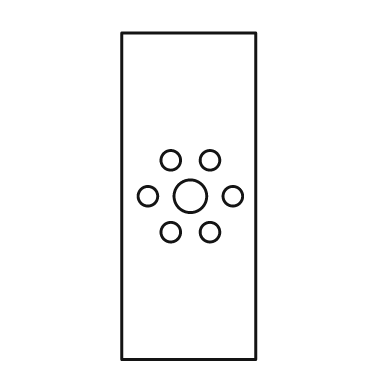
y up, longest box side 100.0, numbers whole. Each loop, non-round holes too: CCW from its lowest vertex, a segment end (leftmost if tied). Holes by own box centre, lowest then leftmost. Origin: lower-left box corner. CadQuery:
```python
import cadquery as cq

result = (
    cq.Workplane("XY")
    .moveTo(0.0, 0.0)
    .lineTo(41.0, 0.0)
    .lineTo(41.0, 100.0)
    .lineTo(0.0, 100.0)
    .close()
    .moveTo(15.0, 39.0)
    .circle(3.0)
    .moveTo(27.0, 39.0)
    .circle(3.0)
    .moveTo(8.0, 50.0)
    .circle(3.0)
    .moveTo(21.0, 50.0)
    .circle(5.0)
    .moveTo(34.0, 50.0)
    .circle(3.0)
    .moveTo(15.0, 61.0)
    .circle(3.0)
    .moveTo(27.0, 61.0)
    .circle(3.0)
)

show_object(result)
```